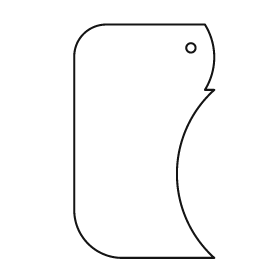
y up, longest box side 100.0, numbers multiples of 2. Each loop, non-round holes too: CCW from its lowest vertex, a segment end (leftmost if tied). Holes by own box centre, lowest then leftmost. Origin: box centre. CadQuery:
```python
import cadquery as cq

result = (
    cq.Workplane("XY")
    .moveTo(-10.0, -50.0)
    .lineTo(30.0, -50.0)
    .threePointArc((14.0, -14.0), (30.0, 22.0))
    .lineTo(26.0, 22.0)
    .threePointArc((30.0, 36.0), (26.0, 50.0))
    .lineTo(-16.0, 50.0)
    .threePointArc((-26.0, 46.0), (-30.0, 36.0))
    .lineTo(-30.0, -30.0)
    .threePointArc((-24.0, -44.0), (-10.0, -50.0))
    .close()
    .moveTo(20.0, 40.0)
    .circle(2.0)
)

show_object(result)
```